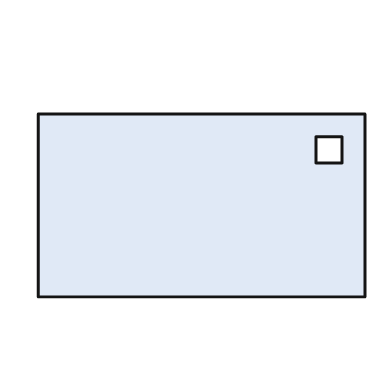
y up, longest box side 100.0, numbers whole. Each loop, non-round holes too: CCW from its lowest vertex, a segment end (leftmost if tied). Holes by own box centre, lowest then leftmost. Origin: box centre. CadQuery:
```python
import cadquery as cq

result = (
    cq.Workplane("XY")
    .moveTo(-50.0, -28.0)
    .lineTo(50.0, -28.0)
    .lineTo(50.0, 28.0)
    .lineTo(-50.0, 28.0)
    .close()
    .moveTo(35.0, 13.0)
    .lineTo(43.0, 13.0)
    .lineTo(43.0, 21.0)
    .lineTo(35.0, 21.0)
    .close()
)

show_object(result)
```